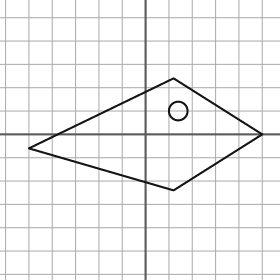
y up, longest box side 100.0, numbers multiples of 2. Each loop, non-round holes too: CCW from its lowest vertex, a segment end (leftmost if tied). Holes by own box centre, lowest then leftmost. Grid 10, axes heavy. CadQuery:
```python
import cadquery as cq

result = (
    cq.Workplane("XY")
    .moveTo(12.0, -24.0)
    .lineTo(50.0, 0.0)
    .lineTo(12.0, 24.0)
    .lineTo(-50.0, -6.0)
    .close()
    .moveTo(14.0, 10.0)
    .circle(4.0)
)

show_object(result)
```